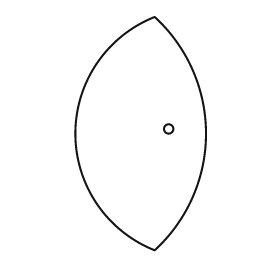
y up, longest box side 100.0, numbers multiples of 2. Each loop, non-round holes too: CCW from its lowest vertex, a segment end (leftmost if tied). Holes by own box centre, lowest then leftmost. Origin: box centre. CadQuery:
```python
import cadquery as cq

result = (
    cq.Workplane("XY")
    .moveTo(6.0, -50.0)
    .threePointArc((28.0, 0.0), (6.0, 50.0))
    .threePointArc((-28.0, 0.0), (6.0, -50.0))
    .close()
    .moveTo(12.0, 2.0)
    .circle(2.0)
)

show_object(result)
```